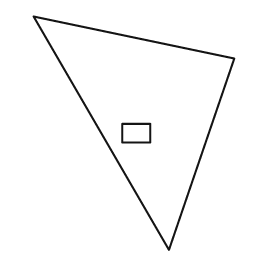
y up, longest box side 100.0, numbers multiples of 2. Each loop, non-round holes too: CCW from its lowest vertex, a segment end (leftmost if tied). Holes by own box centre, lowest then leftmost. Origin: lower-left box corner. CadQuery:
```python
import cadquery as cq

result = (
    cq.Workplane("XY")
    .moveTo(58.0, 0.0)
    .lineTo(86.0, 82.0)
    .lineTo(0.0, 100.0)
    .close()
    .moveTo(38.0, 46.0)
    .lineTo(50.0, 46.0)
    .lineTo(50.0, 54.0)
    .lineTo(38.0, 54.0)
    .close()
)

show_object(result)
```